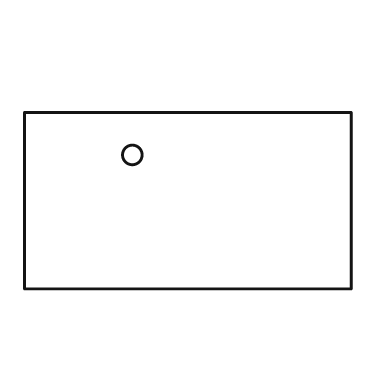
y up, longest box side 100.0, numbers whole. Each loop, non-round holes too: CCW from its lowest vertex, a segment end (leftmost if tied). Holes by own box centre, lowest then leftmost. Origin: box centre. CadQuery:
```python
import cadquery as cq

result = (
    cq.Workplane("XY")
    .moveTo(-50.0, -27.0)
    .lineTo(50.0, -27.0)
    .lineTo(50.0, 27.0)
    .lineTo(-50.0, 27.0)
    .close()
    .moveTo(-17.0, 14.0)
    .circle(3.0)
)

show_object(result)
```